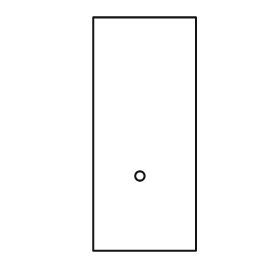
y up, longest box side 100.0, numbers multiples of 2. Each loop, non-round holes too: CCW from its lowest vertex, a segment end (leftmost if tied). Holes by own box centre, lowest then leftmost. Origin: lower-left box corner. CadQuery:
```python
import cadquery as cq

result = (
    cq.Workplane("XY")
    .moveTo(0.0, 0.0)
    .lineTo(44.0, 0.0)
    .lineTo(44.0, 100.0)
    .lineTo(0.0, 100.0)
    .close()
    .moveTo(20.0, 32.0)
    .circle(2.0)
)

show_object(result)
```